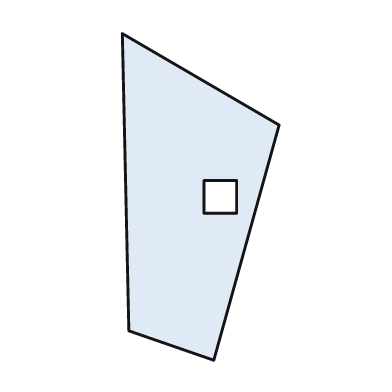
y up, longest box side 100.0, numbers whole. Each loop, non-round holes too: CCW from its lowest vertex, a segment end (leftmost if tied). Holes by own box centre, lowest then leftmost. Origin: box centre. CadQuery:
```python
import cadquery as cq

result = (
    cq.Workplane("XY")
    .moveTo(4.0, -50.0)
    .lineTo(24.0, 22.0)
    .lineTo(-24.0, 50.0)
    .lineTo(-22.0, -41.0)
    .close()
    .moveTo(1.0, -5.0)
    .lineTo(11.0, -5.0)
    .lineTo(11.0, 5.0)
    .lineTo(1.0, 5.0)
    .close()
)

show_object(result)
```